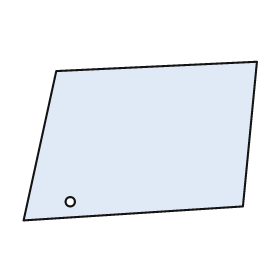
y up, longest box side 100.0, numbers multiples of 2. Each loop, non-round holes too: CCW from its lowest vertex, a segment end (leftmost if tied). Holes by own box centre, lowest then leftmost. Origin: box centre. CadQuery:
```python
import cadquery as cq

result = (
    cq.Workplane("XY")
    .moveTo(-50.0, -34.0)
    .lineTo(44.0, -28.0)
    .lineTo(50.0, 34.0)
    .lineTo(-36.0, 30.0)
    .close()
    .moveTo(-30.0, -26.0)
    .circle(2.0)
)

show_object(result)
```